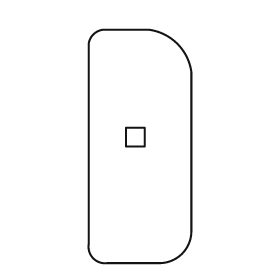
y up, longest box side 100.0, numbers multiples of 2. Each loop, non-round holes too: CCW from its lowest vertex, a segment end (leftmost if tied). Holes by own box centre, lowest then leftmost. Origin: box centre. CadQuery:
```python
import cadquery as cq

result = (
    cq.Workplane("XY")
    .moveTo(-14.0, -50.0)
    .lineTo(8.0, -50.0)
    .threePointArc((18.0, -46.0), (22.0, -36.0))
    .lineTo(22.0, 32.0)
    .threePointArc((16.0, 44.0), (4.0, 50.0))
    .lineTo(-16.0, 50.0)
    .threePointArc((-20.0, 48.0), (-22.0, 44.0))
    .lineTo(-22.0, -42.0)
    .threePointArc((-20.0, -48.0), (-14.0, -50.0))
    .close()
    .moveTo(-6.0, 0.0)
    .lineTo(2.0, 0.0)
    .lineTo(2.0, 8.0)
    .lineTo(-6.0, 8.0)
    .close()
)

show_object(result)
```